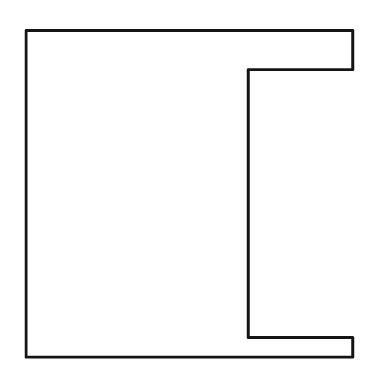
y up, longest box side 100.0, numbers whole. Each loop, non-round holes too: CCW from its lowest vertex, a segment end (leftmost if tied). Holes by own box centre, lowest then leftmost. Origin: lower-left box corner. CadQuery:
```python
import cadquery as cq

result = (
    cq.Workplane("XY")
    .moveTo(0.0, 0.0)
    .lineTo(100.0, 0.0)
    .lineTo(100.0, 6.0)
    .lineTo(68.0, 6.0)
    .lineTo(68.0, 88.0)
    .lineTo(100.0, 88.0)
    .lineTo(100.0, 100.0)
    .lineTo(0.0, 100.0)
    .close()
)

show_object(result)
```